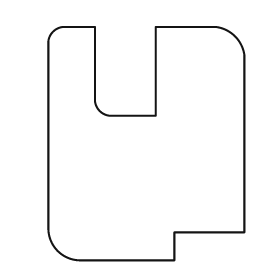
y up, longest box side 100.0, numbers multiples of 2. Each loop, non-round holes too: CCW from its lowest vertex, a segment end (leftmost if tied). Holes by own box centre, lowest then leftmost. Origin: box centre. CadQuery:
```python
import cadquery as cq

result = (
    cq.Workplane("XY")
    .moveTo(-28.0, -50.0)
    .lineTo(12.0, -50.0)
    .lineTo(12.0, -38.0)
    .lineTo(42.0, -38.0)
    .lineTo(42.0, 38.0)
    .threePointArc((38.0, 46.0), (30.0, 50.0))
    .lineTo(4.0, 50.0)
    .lineTo(4.0, 12.0)
    .lineTo(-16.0, 12.0)
    .threePointArc((-20.0, 14.0), (-22.0, 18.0))
    .lineTo(-22.0, 50.0)
    .lineTo(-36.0, 50.0)
    .threePointArc((-40.0, 48.0), (-42.0, 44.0))
    .lineTo(-42.0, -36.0)
    .threePointArc((-38.0, -46.0), (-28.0, -50.0))
    .close()
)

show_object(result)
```